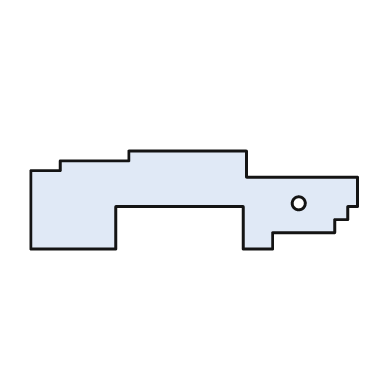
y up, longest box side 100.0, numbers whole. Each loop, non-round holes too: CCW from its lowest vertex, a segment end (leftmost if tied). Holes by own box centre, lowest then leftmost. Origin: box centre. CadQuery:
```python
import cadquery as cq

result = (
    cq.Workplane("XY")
    .moveTo(-50.0, -15.0)
    .lineTo(-24.0, -15.0)
    .lineTo(-24.0, -2.0)
    .lineTo(15.0, -2.0)
    .lineTo(15.0, -15.0)
    .lineTo(24.0, -15.0)
    .lineTo(24.0, -10.0)
    .lineTo(43.0, -10.0)
    .lineTo(43.0, -6.0)
    .lineTo(47.0, -6.0)
    .lineTo(47.0, -2.0)
    .lineTo(50.0, -2.0)
    .lineTo(50.0, 7.0)
    .lineTo(16.0, 7.0)
    .lineTo(16.0, 15.0)
    .lineTo(-20.0, 15.0)
    .lineTo(-20.0, 12.0)
    .lineTo(-41.0, 12.0)
    .lineTo(-41.0, 9.0)
    .lineTo(-50.0, 9.0)
    .close()
    .moveTo(32.0, -1.0)
    .circle(2.0)
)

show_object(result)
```